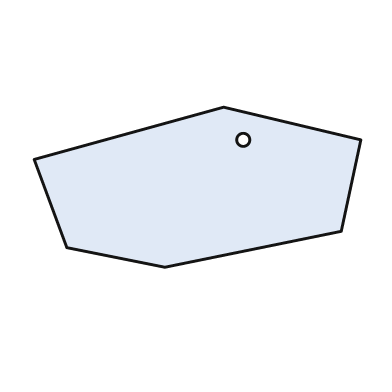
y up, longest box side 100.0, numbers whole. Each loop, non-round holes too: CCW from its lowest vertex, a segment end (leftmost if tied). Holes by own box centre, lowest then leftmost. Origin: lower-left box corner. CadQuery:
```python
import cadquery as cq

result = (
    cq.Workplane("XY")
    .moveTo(40.0, 0.0)
    .lineTo(94.0, 11.0)
    .lineTo(100.0, 39.0)
    .lineTo(58.0, 49.0)
    .lineTo(0.0, 33.0)
    .lineTo(10.0, 6.0)
    .close()
    .moveTo(64.0, 39.0)
    .circle(2.0)
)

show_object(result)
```